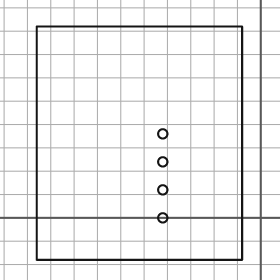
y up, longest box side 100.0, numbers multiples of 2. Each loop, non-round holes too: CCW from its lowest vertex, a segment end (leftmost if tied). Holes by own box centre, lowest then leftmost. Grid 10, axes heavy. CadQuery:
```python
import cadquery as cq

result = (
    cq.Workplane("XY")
    .moveTo(-96.0, -18.0)
    .lineTo(-8.0, -18.0)
    .lineTo(-8.0, 82.0)
    .lineTo(-96.0, 82.0)
    .close()
    .moveTo(-42.0, 0.0)
    .circle(2.0)
    .moveTo(-42.0, 12.0)
    .circle(2.0)
    .moveTo(-42.0, 24.0)
    .circle(2.0)
    .moveTo(-42.0, 36.0)
    .circle(2.0)
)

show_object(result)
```